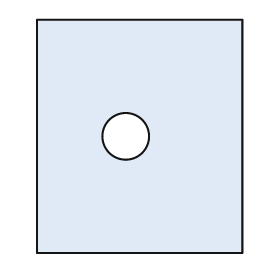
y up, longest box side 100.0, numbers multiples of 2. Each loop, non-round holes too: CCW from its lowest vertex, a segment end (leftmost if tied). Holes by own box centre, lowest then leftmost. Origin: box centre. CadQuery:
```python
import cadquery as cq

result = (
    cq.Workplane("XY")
    .moveTo(-44.0, -50.0)
    .lineTo(44.0, -50.0)
    .lineTo(44.0, 50.0)
    .lineTo(-44.0, 50.0)
    .close()
    .moveTo(-6.0, 0.0)
    .circle(10.0)
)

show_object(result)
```